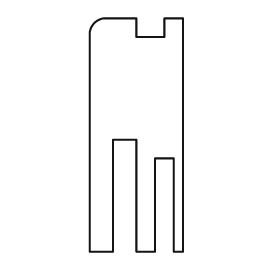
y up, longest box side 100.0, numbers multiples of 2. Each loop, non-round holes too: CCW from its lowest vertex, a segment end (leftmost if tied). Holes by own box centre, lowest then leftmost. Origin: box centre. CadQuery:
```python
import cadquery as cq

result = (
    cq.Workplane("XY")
    .moveTo(-20.0, -50.0)
    .lineTo(-10.0, -50.0)
    .lineTo(-10.0, -2.0)
    .lineTo(0.0, -2.0)
    .lineTo(0.0, -50.0)
    .lineTo(8.0, -50.0)
    .lineTo(8.0, -10.0)
    .lineTo(16.0, -10.0)
    .lineTo(16.0, -50.0)
    .lineTo(20.0, -50.0)
    .lineTo(20.0, 50.0)
    .lineTo(12.0, 50.0)
    .lineTo(12.0, 42.0)
    .lineTo(0.0, 42.0)
    .lineTo(0.0, 50.0)
    .lineTo(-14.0, 50.0)
    .threePointArc((-18.0, 48.0), (-20.0, 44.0))
    .close()
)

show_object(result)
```